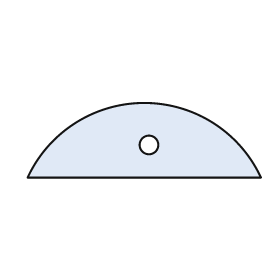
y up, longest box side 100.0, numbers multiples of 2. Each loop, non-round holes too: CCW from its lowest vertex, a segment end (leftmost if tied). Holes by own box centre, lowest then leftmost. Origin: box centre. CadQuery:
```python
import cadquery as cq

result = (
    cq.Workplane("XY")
    .moveTo(-50.0, -16.0)
    .lineTo(50.0, -16.0)
    .threePointArc((0.0, 16.0), (-50.0, -16.0))
    .close()
    .moveTo(2.0, -2.0)
    .circle(4.0)
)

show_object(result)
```